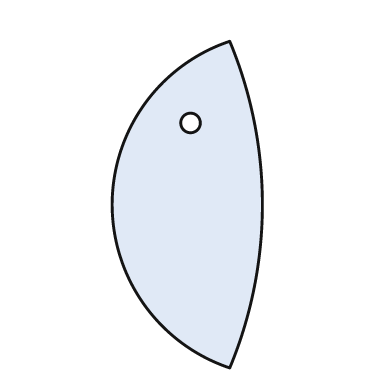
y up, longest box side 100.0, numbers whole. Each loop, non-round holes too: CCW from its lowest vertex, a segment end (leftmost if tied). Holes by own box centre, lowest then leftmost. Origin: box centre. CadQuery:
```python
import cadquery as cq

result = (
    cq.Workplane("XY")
    .moveTo(13.0, -50.0)
    .threePointArc((23.0, 0.0), (13.0, 50.0))
    .threePointArc((-23.0, 0.0), (13.0, -50.0))
    .close()
    .moveTo(1.0, 25.0)
    .circle(3.0)
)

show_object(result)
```